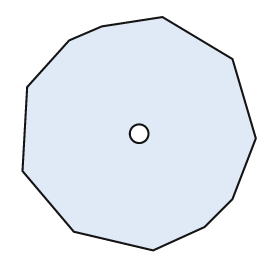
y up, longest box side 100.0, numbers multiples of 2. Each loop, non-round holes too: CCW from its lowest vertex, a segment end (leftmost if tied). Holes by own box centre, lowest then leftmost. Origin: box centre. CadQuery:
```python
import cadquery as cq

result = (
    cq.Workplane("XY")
    .moveTo(6.0, -50.0)
    .lineTo(28.0, -40.0)
    .lineTo(40.0, -28.0)
    .lineTo(50.0, -2.0)
    .lineTo(40.0, 32.0)
    .lineTo(10.0, 50.0)
    .lineTo(-16.0, 46.0)
    .lineTo(-30.0, 40.0)
    .lineTo(-48.0, 20.0)
    .lineTo(-50.0, -16.0)
    .lineTo(-28.0, -42.0)
    .close()
    .moveTo(0.0, 0.0)
    .circle(4.0)
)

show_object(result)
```